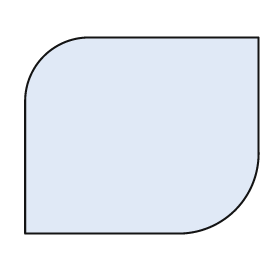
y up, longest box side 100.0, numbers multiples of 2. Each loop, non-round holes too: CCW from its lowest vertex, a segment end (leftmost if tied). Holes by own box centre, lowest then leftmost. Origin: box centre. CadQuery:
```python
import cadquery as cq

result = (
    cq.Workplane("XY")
    .moveTo(-50.0, -42.0)
    .lineTo(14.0, -42.0)
    .threePointArc((40.0, -32.0), (50.0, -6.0))
    .lineTo(50.0, 42.0)
    .lineTo(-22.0, 42.0)
    .threePointArc((-42.0, 34.0), (-50.0, 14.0))
    .close()
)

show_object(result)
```